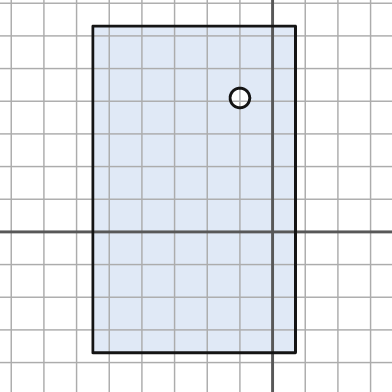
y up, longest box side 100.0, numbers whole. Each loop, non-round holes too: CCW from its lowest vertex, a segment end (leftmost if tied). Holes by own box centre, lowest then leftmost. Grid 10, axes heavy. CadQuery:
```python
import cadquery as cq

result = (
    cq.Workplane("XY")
    .moveTo(-55.0, -37.0)
    .lineTo(7.0, -37.0)
    .lineTo(7.0, 63.0)
    .lineTo(-55.0, 63.0)
    .close()
    .moveTo(-10.0, 41.0)
    .circle(3.0)
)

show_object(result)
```